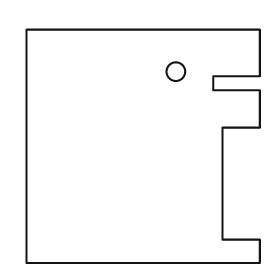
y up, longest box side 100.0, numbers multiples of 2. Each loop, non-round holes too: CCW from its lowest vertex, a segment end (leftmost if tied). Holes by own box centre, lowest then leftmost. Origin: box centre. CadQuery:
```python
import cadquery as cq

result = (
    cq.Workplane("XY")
    .moveTo(-50.0, -50.0)
    .lineTo(50.0, -50.0)
    .lineTo(50.0, -40.0)
    .lineTo(34.0, -40.0)
    .lineTo(34.0, 8.0)
    .lineTo(50.0, 8.0)
    .lineTo(50.0, 24.0)
    .lineTo(30.0, 24.0)
    .lineTo(30.0, 30.0)
    .lineTo(50.0, 30.0)
    .lineTo(50.0, 50.0)
    .lineTo(-50.0, 50.0)
    .close()
    .moveTo(14.0, 32.0)
    .circle(4.0)
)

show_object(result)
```